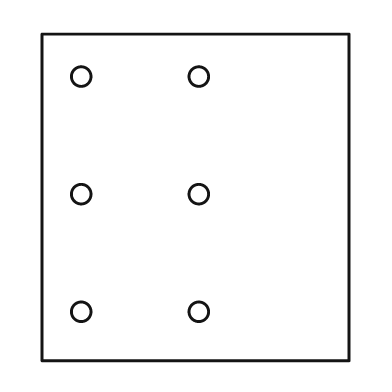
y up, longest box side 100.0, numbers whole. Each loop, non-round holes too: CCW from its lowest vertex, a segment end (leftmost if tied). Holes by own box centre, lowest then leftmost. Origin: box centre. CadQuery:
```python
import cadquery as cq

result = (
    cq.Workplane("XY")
    .moveTo(-47.0, -50.0)
    .lineTo(47.0, -50.0)
    .lineTo(47.0, 50.0)
    .lineTo(-47.0, 50.0)
    .close()
    .moveTo(-35.0, -35.0)
    .circle(3.0)
    .moveTo(1.0, -35.0)
    .circle(3.0)
    .moveTo(-35.0, 1.0)
    .circle(3.0)
    .moveTo(1.0, 1.0)
    .circle(3.0)
    .moveTo(-35.0, 37.0)
    .circle(3.0)
    .moveTo(1.0, 37.0)
    .circle(3.0)
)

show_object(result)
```